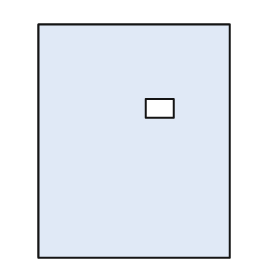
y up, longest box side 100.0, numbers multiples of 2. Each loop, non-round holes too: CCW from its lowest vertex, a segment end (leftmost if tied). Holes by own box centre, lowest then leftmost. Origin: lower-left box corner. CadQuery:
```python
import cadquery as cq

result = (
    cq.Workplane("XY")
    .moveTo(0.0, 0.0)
    .lineTo(82.0, 0.0)
    .lineTo(82.0, 100.0)
    .lineTo(0.0, 100.0)
    .close()
    .moveTo(46.0, 60.0)
    .lineTo(58.0, 60.0)
    .lineTo(58.0, 68.0)
    .lineTo(46.0, 68.0)
    .close()
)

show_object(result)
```